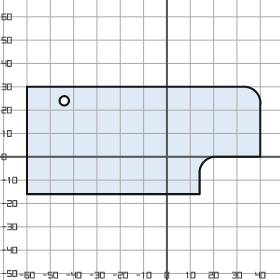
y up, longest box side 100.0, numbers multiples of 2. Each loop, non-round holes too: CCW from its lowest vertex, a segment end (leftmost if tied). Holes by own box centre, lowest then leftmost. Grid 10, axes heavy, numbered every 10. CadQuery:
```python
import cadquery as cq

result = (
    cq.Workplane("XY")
    .moveTo(-60.0, -16.0)
    .lineTo(14.0, -16.0)
    .lineTo(14.0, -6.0)
    .threePointArc((16.0, -2.0), (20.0, 0.0))
    .lineTo(40.0, 0.0)
    .lineTo(40.0, 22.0)
    .threePointArc((38.0, 28.0), (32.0, 30.0))
    .lineTo(-60.0, 30.0)
    .close()
    .moveTo(-44.0, 24.0)
    .circle(2.0)
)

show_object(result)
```